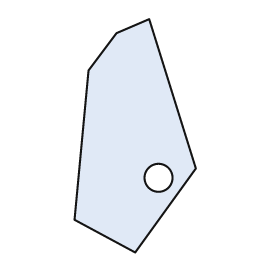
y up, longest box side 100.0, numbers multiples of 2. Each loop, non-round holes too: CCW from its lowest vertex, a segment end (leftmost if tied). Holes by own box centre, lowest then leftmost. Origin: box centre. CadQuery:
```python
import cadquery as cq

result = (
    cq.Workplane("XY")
    .moveTo(0.0, -50.0)
    .lineTo(26.0, -14.0)
    .lineTo(6.0, 50.0)
    .lineTo(-8.0, 44.0)
    .lineTo(-20.0, 28.0)
    .lineTo(-26.0, -36.0)
    .close()
    .moveTo(10.0, -18.0)
    .circle(6.0)
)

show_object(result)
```